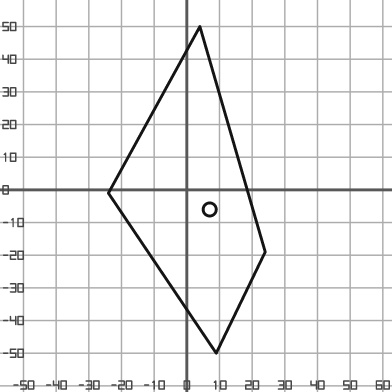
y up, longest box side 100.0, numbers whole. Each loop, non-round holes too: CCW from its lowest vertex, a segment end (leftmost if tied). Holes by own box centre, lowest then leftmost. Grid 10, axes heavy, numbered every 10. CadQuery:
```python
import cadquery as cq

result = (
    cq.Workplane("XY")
    .moveTo(9.0, -50.0)
    .lineTo(24.0, -19.0)
    .lineTo(4.0, 50.0)
    .lineTo(-24.0, -1.0)
    .close()
    .moveTo(7.0, -6.0)
    .circle(2.0)
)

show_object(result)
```